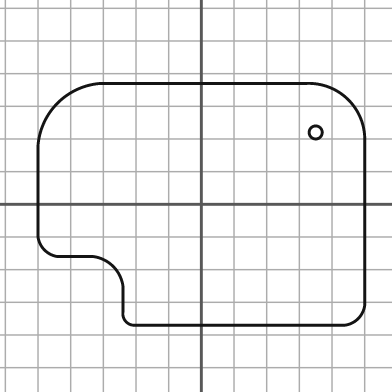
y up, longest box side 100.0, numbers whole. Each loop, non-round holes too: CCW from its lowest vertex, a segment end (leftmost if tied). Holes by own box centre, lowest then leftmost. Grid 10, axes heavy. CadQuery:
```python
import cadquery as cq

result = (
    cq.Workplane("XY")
    .moveTo(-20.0, -37.0)
    .lineTo(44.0, -37.0)
    .threePointArc((48.0, -35.0), (50.0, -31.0))
    .lineTo(50.0, 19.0)
    .threePointArc((45.0, 32.0), (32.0, 37.0))
    .lineTo(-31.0, 37.0)
    .threePointArc((-44.0, 31.0), (-50.0, 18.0))
    .lineTo(-50.0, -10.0)
    .threePointArc((-48.0, -14.0), (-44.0, -16.0))
    .lineTo(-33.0, -16.0)
    .threePointArc((-27.0, -19.0), (-24.0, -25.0))
    .lineTo(-24.0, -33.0)
    .threePointArc((-23.0, -36.0), (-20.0, -37.0))
    .close()
    .moveTo(35.0, 22.0)
    .circle(2.0)
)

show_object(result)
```